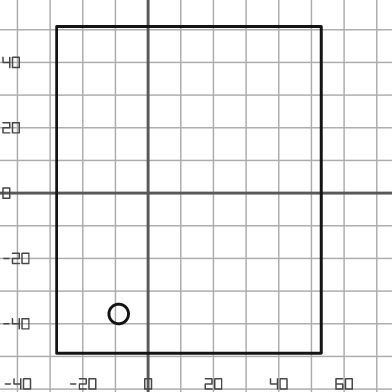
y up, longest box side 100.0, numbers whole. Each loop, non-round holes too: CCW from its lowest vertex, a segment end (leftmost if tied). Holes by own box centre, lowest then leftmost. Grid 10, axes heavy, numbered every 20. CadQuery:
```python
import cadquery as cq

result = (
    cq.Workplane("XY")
    .moveTo(-28.0, -49.0)
    .lineTo(53.0, -49.0)
    .lineTo(53.0, 51.0)
    .lineTo(-28.0, 51.0)
    .close()
    .moveTo(-9.0, -37.0)
    .circle(3.0)
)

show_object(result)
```